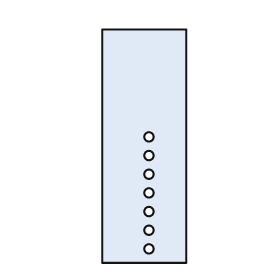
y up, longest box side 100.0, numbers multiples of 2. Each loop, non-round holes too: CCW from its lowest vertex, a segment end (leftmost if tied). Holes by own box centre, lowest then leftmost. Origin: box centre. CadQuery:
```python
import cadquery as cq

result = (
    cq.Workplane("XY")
    .moveTo(-18.0, -50.0)
    .lineTo(18.0, -50.0)
    .lineTo(18.0, 50.0)
    .lineTo(-18.0, 50.0)
    .close()
    .moveTo(2.0, -44.0)
    .circle(2.0)
    .moveTo(2.0, -36.0)
    .circle(2.0)
    .moveTo(2.0, -28.0)
    .circle(2.0)
    .moveTo(2.0, -20.0)
    .circle(2.0)
    .moveTo(2.0, -12.0)
    .circle(2.0)
    .moveTo(2.0, -4.0)
    .circle(2.0)
    .moveTo(2.0, 4.0)
    .circle(2.0)
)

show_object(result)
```